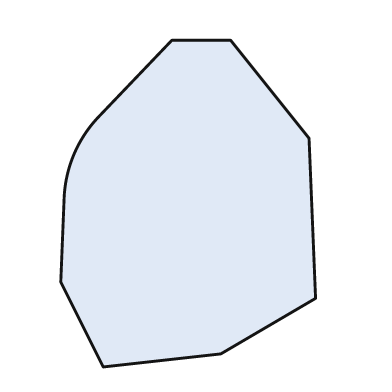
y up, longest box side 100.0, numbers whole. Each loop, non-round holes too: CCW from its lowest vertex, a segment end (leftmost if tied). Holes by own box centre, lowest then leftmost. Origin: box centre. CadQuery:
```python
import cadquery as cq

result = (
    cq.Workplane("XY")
    .moveTo(-26.0, -50.0)
    .lineTo(10.0, -46.0)
    .lineTo(39.0, -29.0)
    .lineTo(37.0, 20.0)
    .lineTo(13.0, 50.0)
    .lineTo(-5.0, 50.0)
    .lineTo(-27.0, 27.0)
    .threePointArc((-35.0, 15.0), (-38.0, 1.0))
    .lineTo(-39.0, -24.0)
    .close()
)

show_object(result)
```